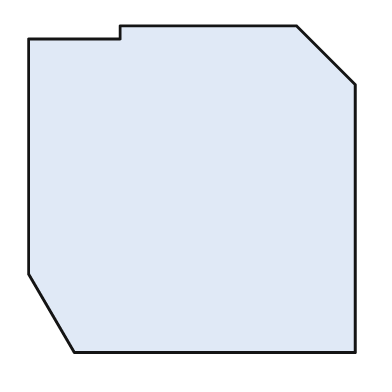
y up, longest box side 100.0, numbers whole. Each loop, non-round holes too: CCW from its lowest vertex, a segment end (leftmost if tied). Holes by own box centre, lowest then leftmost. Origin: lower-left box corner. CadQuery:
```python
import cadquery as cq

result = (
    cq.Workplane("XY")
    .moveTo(14.0, 0.0)
    .lineTo(100.0, 0.0)
    .lineTo(100.0, 82.0)
    .lineTo(82.0, 100.0)
    .lineTo(28.0, 100.0)
    .lineTo(28.0, 96.0)
    .lineTo(0.0, 96.0)
    .lineTo(0.0, 24.0)
    .close()
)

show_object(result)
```